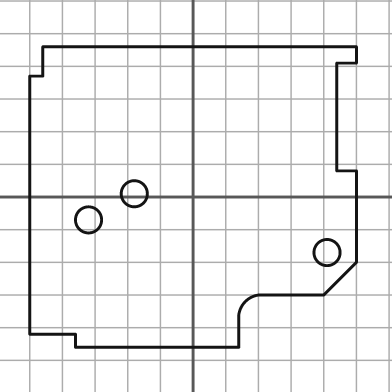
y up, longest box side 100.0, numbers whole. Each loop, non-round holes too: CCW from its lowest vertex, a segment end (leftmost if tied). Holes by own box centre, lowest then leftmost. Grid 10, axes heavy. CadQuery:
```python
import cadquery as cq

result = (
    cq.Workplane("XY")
    .moveTo(-36.0, -46.0)
    .lineTo(14.0, -46.0)
    .lineTo(14.0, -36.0)
    .threePointArc((16.0, -32.0), (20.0, -30.0))
    .lineTo(40.0, -30.0)
    .lineTo(50.0, -20.0)
    .lineTo(50.0, 8.0)
    .lineTo(44.0, 8.0)
    .lineTo(44.0, 41.0)
    .lineTo(50.0, 41.0)
    .lineTo(50.0, 46.0)
    .lineTo(-46.0, 46.0)
    .lineTo(-46.0, 37.0)
    .lineTo(-50.0, 37.0)
    .lineTo(-50.0, -42.0)
    .lineTo(-36.0, -42.0)
    .close()
    .moveTo(41.0, -17.0)
    .circle(4.0)
    .moveTo(-32.0, -7.0)
    .circle(4.0)
    .moveTo(-18.0, 1.0)
    .circle(4.0)
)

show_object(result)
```